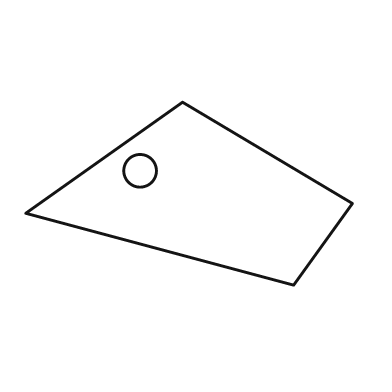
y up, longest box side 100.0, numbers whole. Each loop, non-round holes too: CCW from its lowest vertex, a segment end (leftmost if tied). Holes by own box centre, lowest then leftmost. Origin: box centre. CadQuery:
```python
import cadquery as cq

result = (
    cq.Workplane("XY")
    .moveTo(32.0, -28.0)
    .lineTo(50.0, -3.0)
    .lineTo(-2.0, 28.0)
    .lineTo(-50.0, -6.0)
    .close()
    .moveTo(-15.0, 7.0)
    .circle(5.0)
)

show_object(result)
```